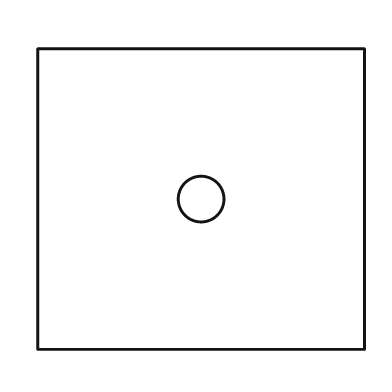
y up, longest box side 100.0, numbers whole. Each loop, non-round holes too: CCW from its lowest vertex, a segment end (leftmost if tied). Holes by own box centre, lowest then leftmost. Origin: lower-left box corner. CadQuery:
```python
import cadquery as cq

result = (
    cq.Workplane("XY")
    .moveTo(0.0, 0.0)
    .lineTo(100.0, 0.0)
    .lineTo(100.0, 92.0)
    .lineTo(0.0, 92.0)
    .close()
    .moveTo(50.0, 46.0)
    .circle(7.0)
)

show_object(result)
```